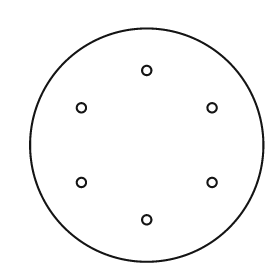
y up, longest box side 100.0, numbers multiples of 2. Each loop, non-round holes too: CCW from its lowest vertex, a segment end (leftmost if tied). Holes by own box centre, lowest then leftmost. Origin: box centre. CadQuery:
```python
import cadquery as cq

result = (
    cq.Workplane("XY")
    .moveTo(0.0, 0.0)
    .circle(50.0)
    .moveTo(0.0, -32.0)
    .circle(2.0)
    .moveTo(-28.0, -16.0)
    .circle(2.0)
    .moveTo(28.0, -16.0)
    .circle(2.0)
    .moveTo(-28.0, 16.0)
    .circle(2.0)
    .moveTo(28.0, 16.0)
    .circle(2.0)
    .moveTo(0.0, 32.0)
    .circle(2.0)
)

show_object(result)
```